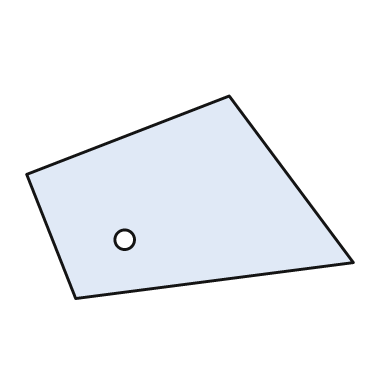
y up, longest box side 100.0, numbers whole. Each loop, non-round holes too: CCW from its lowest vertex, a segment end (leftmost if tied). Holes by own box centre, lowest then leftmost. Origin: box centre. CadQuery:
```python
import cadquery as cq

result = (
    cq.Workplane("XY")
    .moveTo(-35.0, -31.0)
    .lineTo(50.0, -20.0)
    .lineTo(12.0, 31.0)
    .lineTo(-50.0, 7.0)
    .close()
    .moveTo(-20.0, -13.0)
    .circle(3.0)
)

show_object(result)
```